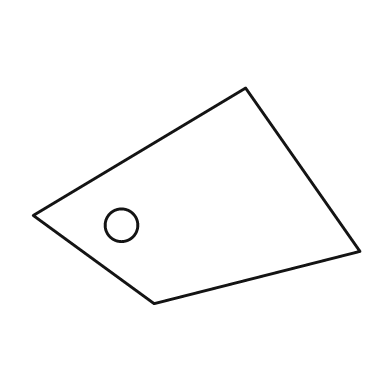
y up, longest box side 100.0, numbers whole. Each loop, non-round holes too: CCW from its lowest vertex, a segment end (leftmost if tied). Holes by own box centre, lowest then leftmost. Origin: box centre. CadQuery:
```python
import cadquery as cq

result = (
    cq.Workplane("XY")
    .moveTo(-13.0, -33.0)
    .lineTo(50.0, -17.0)
    .lineTo(15.0, 33.0)
    .lineTo(-50.0, -6.0)
    .close()
    .moveTo(-23.0, -9.0)
    .circle(5.0)
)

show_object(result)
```